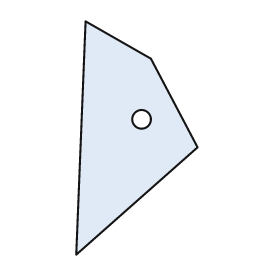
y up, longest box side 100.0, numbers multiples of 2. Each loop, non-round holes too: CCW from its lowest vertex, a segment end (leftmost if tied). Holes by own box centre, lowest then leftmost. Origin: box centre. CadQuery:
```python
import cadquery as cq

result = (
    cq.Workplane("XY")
    .moveTo(-26.0, -50.0)
    .lineTo(26.0, -4.0)
    .lineTo(6.0, 34.0)
    .lineTo(-22.0, 50.0)
    .close()
    .moveTo(2.0, 8.0)
    .circle(4.0)
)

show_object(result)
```